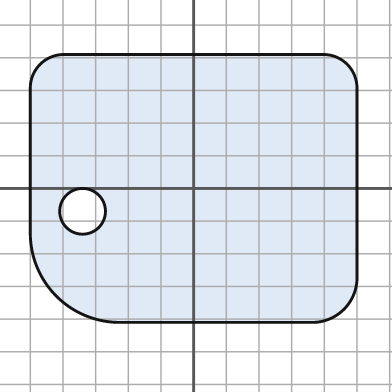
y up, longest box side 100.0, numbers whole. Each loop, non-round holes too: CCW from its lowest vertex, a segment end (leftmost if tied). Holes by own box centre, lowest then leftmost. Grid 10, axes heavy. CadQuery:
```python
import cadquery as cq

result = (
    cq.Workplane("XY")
    .moveTo(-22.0, -41.0)
    .lineTo(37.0, -41.0)
    .threePointArc((46.0, -37.0), (50.0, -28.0))
    .lineTo(50.0, 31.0)
    .threePointArc((47.0, 38.0), (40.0, 41.0))
    .lineTo(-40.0, 41.0)
    .threePointArc((-47.0, 38.0), (-50.0, 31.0))
    .lineTo(-50.0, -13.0)
    .threePointArc((-42.0, -33.0), (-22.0, -41.0))
    .close()
    .moveTo(-34.0, -7.0)
    .circle(7.0)
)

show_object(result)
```